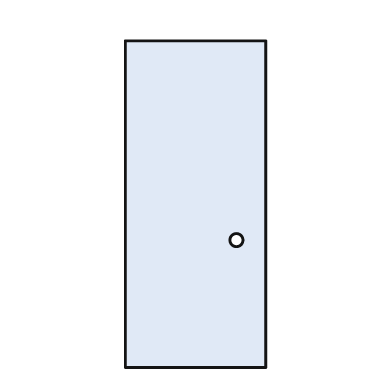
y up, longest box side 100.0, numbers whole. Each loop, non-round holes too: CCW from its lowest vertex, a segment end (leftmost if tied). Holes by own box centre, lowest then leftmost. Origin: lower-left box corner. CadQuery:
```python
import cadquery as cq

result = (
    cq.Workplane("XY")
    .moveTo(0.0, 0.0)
    .lineTo(43.0, 0.0)
    .lineTo(43.0, 100.0)
    .lineTo(0.0, 100.0)
    .close()
    .moveTo(34.0, 39.0)
    .circle(2.0)
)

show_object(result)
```